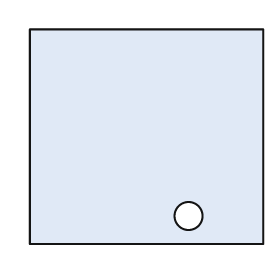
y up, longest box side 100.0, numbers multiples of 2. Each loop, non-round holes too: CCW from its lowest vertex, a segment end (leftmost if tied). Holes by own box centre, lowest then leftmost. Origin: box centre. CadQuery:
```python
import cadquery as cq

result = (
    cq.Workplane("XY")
    .moveTo(-50.0, -46.0)
    .lineTo(50.0, -46.0)
    .lineTo(50.0, 46.0)
    .lineTo(-50.0, 46.0)
    .close()
    .moveTo(18.0, -34.0)
    .circle(6.0)
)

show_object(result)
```